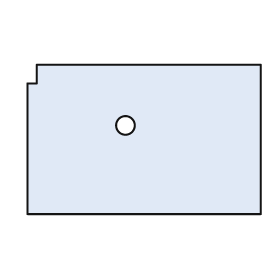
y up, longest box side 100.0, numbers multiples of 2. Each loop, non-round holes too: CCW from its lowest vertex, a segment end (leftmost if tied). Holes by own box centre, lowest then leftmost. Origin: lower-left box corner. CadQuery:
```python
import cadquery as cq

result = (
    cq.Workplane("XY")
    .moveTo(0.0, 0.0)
    .lineTo(100.0, 0.0)
    .lineTo(100.0, 64.0)
    .lineTo(4.0, 64.0)
    .lineTo(4.0, 56.0)
    .lineTo(0.0, 56.0)
    .close()
    .moveTo(42.0, 38.0)
    .circle(4.0)
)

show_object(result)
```